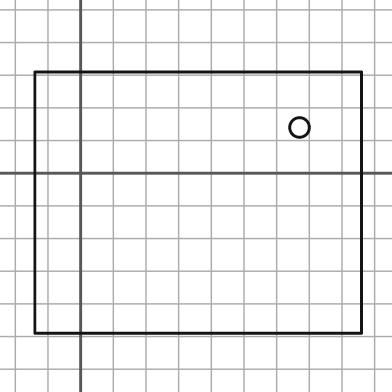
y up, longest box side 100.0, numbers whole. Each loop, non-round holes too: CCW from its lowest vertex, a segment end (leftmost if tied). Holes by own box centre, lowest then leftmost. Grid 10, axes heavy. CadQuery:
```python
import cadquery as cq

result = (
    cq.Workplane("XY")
    .moveTo(-14.0, -49.0)
    .lineTo(86.0, -49.0)
    .lineTo(86.0, 31.0)
    .lineTo(-14.0, 31.0)
    .close()
    .moveTo(67.0, 14.0)
    .circle(3.0)
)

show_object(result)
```